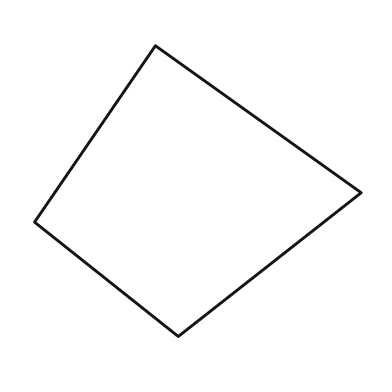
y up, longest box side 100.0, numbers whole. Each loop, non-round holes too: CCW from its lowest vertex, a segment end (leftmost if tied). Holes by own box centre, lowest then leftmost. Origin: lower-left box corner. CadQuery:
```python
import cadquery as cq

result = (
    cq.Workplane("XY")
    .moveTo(44.0, 0.0)
    .lineTo(100.0, 44.0)
    .lineTo(37.0, 89.0)
    .lineTo(0.0, 35.0)
    .close()
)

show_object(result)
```